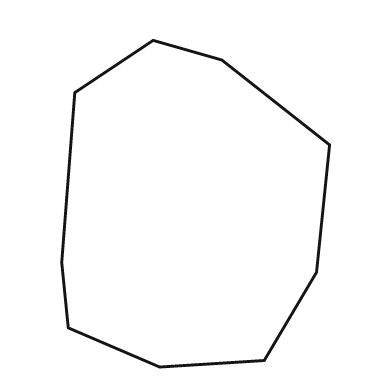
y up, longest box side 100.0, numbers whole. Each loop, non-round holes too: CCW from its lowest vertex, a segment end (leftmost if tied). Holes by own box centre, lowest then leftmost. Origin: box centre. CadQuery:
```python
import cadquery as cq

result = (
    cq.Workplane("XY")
    .moveTo(-11.0, -50.0)
    .lineTo(21.0, -48.0)
    .lineTo(37.0, -21.0)
    .lineTo(41.0, 18.0)
    .lineTo(8.0, 44.0)
    .lineTo(-13.0, 50.0)
    .lineTo(-37.0, 34.0)
    .lineTo(-41.0, -18.0)
    .lineTo(-39.0, -38.0)
    .close()
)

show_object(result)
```